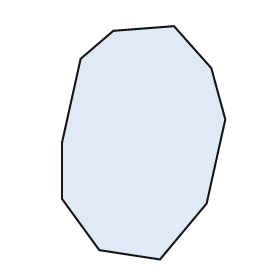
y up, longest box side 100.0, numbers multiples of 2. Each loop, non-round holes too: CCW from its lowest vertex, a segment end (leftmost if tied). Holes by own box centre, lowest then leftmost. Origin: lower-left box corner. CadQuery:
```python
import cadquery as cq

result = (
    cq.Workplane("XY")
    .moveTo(42.0, 0.0)
    .lineTo(62.0, 24.0)
    .lineTo(70.0, 60.0)
    .lineTo(64.0, 82.0)
    .lineTo(48.0, 100.0)
    .lineTo(22.0, 98.0)
    .lineTo(8.0, 86.0)
    .lineTo(0.0, 50.0)
    .lineTo(0.0, 26.0)
    .lineTo(16.0, 4.0)
    .close()
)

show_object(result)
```